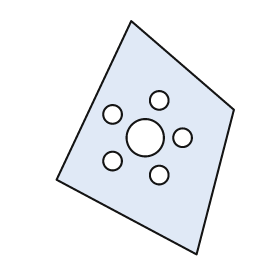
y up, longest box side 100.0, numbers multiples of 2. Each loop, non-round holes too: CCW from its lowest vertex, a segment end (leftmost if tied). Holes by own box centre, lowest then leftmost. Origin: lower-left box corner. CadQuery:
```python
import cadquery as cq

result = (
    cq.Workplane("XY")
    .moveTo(60.0, 0.0)
    .lineTo(76.0, 62.0)
    .lineTo(32.0, 100.0)
    .lineTo(0.0, 32.0)
    .close()
    .moveTo(44.0, 34.0)
    .circle(4.0)
    .moveTo(24.0, 40.0)
    .circle(4.0)
    .moveTo(38.0, 50.0)
    .circle(8.0)
    .moveTo(54.0, 50.0)
    .circle(4.0)
    .moveTo(24.0, 60.0)
    .circle(4.0)
    .moveTo(44.0, 66.0)
    .circle(4.0)
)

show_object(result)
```